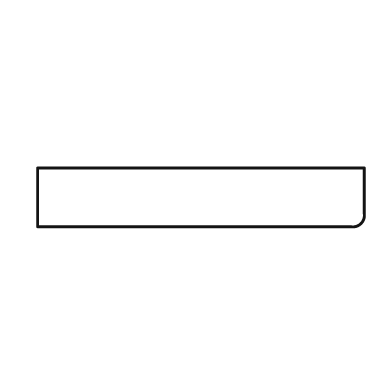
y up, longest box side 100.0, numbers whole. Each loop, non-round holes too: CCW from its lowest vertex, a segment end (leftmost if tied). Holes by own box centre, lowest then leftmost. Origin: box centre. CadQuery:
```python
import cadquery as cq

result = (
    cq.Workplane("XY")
    .moveTo(-50.0, -9.0)
    .lineTo(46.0, -9.0)
    .threePointArc((49.0, -8.0), (50.0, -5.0))
    .lineTo(50.0, 9.0)
    .lineTo(-50.0, 9.0)
    .close()
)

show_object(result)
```